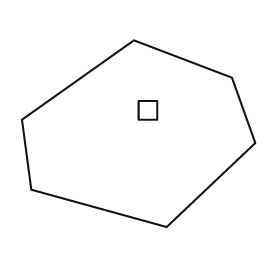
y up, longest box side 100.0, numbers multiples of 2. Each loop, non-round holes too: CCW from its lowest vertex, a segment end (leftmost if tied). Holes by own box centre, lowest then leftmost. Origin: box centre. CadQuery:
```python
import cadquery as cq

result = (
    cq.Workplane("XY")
    .moveTo(12.0, -40.0)
    .lineTo(50.0, -4.0)
    .lineTo(40.0, 24.0)
    .lineTo(-2.0, 40.0)
    .lineTo(-50.0, 6.0)
    .lineTo(-46.0, -24.0)
    .close()
    .moveTo(0.0, 6.0)
    .lineTo(8.0, 6.0)
    .lineTo(8.0, 14.0)
    .lineTo(0.0, 14.0)
    .close()
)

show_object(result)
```